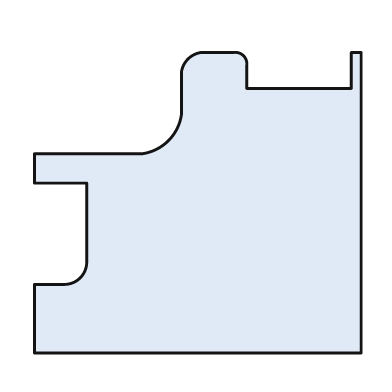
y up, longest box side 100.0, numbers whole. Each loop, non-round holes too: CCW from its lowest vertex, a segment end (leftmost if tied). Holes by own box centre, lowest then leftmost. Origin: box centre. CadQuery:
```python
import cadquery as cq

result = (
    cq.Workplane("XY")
    .moveTo(-50.0, -46.0)
    .lineTo(50.0, -46.0)
    .lineTo(50.0, 46.0)
    .lineTo(47.0, 46.0)
    .lineTo(47.0, 35.0)
    .lineTo(15.0, 35.0)
    .lineTo(15.0, 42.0)
    .threePointArc((14.0, 45.0), (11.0, 46.0))
    .lineTo(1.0, 46.0)
    .threePointArc((-3.0, 44.0), (-5.0, 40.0))
    .lineTo(-5.0, 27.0)
    .threePointArc((-9.0, 19.0), (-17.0, 15.0))
    .lineTo(-50.0, 15.0)
    .lineTo(-50.0, 6.0)
    .lineTo(-34.0, 6.0)
    .lineTo(-34.0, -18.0)
    .threePointArc((-36.0, -23.0), (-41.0, -25.0))
    .lineTo(-50.0, -25.0)
    .close()
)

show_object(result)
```